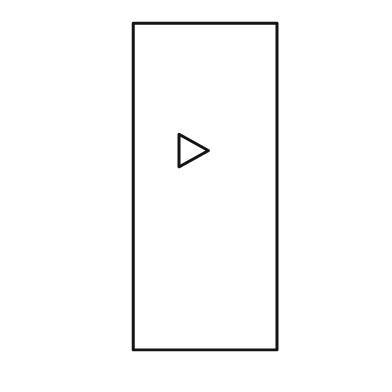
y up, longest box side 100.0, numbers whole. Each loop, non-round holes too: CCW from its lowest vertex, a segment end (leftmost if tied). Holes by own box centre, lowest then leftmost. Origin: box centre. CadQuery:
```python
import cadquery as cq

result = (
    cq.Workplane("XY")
    .moveTo(-22.0, -50.0)
    .lineTo(22.0, -50.0)
    .lineTo(22.0, 50.0)
    .lineTo(-22.0, 50.0)
    .close()
    .moveTo(-8.0, 6.0)
    .lineTo(1.0, 11.0)
    .lineTo(-8.0, 16.0)
    .close()
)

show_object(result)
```